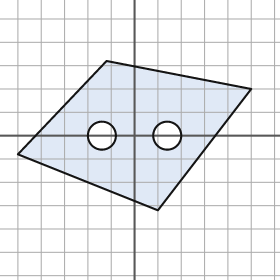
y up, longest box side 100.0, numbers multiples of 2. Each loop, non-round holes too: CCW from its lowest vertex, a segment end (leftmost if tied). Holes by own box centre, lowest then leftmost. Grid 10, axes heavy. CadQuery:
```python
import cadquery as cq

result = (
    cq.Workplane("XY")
    .moveTo(10.0, -32.0)
    .lineTo(50.0, 20.0)
    .lineTo(-12.0, 32.0)
    .lineTo(-50.0, -8.0)
    .close()
    .moveTo(-14.0, 0.0)
    .circle(6.0)
    .moveTo(14.0, 0.0)
    .circle(6.0)
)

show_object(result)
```